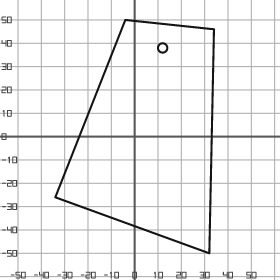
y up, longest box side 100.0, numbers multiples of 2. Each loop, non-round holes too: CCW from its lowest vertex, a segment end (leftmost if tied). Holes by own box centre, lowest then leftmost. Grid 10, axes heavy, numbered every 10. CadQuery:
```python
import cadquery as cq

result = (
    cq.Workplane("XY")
    .moveTo(32.0, -50.0)
    .lineTo(34.0, 46.0)
    .lineTo(-4.0, 50.0)
    .lineTo(-34.0, -26.0)
    .close()
    .moveTo(12.0, 38.0)
    .circle(2.0)
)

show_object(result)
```